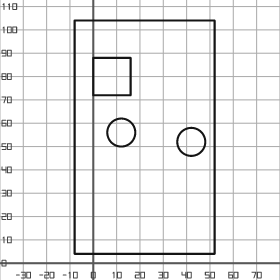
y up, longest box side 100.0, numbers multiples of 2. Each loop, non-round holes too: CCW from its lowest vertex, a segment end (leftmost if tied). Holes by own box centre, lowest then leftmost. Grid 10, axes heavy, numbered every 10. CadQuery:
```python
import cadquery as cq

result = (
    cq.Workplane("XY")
    .moveTo(-8.0, 4.0)
    .lineTo(52.0, 4.0)
    .lineTo(52.0, 104.0)
    .lineTo(-8.0, 104.0)
    .close()
    .moveTo(42.0, 52.0)
    .circle(6.0)
    .moveTo(12.0, 56.0)
    .circle(6.0)
    .moveTo(0.0, 72.0)
    .lineTo(16.0, 72.0)
    .lineTo(16.0, 88.0)
    .lineTo(0.0, 88.0)
    .close()
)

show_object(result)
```